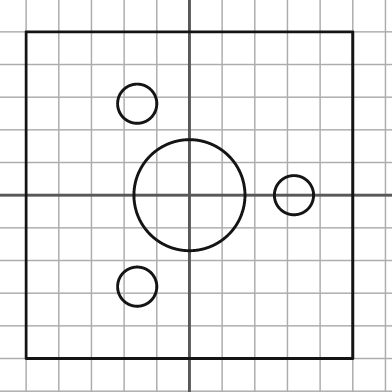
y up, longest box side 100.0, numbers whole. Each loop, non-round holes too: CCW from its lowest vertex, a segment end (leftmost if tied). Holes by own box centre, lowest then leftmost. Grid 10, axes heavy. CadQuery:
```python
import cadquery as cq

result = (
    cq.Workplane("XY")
    .moveTo(-50.0, -50.0)
    .lineTo(50.0, -50.0)
    .lineTo(50.0, 50.0)
    .lineTo(-50.0, 50.0)
    .close()
    .moveTo(-16.0, -28.0)
    .circle(6.0)
    .moveTo(0.0, 0.0)
    .circle(17.0)
    .moveTo(32.0, 0.0)
    .circle(6.0)
    .moveTo(-16.0, 28.0)
    .circle(6.0)
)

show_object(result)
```